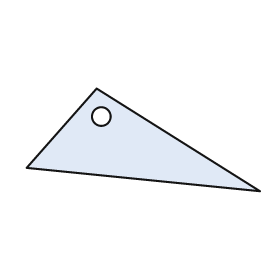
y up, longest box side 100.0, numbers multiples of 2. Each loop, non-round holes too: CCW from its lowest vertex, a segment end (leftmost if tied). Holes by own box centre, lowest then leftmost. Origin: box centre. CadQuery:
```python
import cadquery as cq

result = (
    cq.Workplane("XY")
    .moveTo(50.0, -22.0)
    .lineTo(-20.0, 22.0)
    .lineTo(-50.0, -12.0)
    .close()
    .moveTo(-18.0, 10.0)
    .circle(4.0)
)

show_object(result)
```